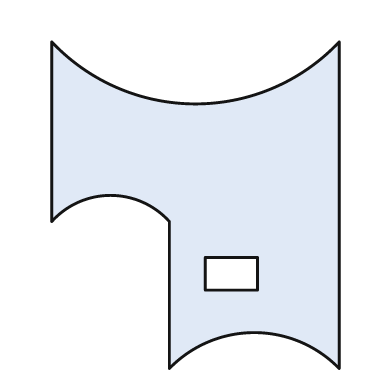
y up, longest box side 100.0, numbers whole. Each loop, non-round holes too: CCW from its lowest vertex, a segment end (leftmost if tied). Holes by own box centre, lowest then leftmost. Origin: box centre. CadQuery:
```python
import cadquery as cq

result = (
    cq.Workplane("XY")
    .moveTo(-8.0, -50.0)
    .threePointArc((18.0, -39.0), (44.0, -50.0))
    .lineTo(44.0, 50.0)
    .threePointArc((0.0, 31.0), (-44.0, 50.0))
    .lineTo(-44.0, -5.0)
    .threePointArc((-26.0, 3.0), (-8.0, -5.0))
    .close()
    .moveTo(3.0, -26.0)
    .lineTo(19.0, -26.0)
    .lineTo(19.0, -16.0)
    .lineTo(3.0, -16.0)
    .close()
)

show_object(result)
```